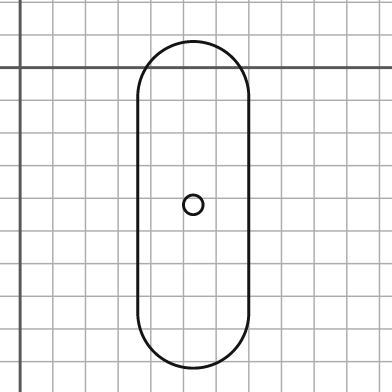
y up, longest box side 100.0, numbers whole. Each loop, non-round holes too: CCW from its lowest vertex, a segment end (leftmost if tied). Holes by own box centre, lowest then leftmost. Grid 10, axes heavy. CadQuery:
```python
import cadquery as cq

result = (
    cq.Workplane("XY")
    .moveTo(36.0, -75.0)
    .threePointArc((53.0, -92.0), (70.0, -75.0))
    .lineTo(70.0, -9.0)
    .threePointArc((53.0, 8.0), (36.0, -9.0))
    .close()
    .moveTo(53.0, -42.0)
    .circle(3.0)
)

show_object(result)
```